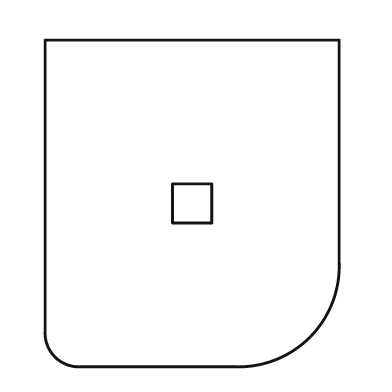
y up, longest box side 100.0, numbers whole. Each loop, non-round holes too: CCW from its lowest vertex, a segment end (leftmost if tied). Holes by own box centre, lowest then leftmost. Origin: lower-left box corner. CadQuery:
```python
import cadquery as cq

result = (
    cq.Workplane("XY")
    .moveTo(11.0, 0.0)
    .lineTo(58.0, 0.0)
    .threePointArc((81.0, 9.0), (90.0, 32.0))
    .lineTo(90.0, 100.0)
    .lineTo(0.0, 100.0)
    .lineTo(0.0, 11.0)
    .threePointArc((3.0, 3.0), (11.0, 0.0))
    .close()
    .moveTo(39.0, 44.0)
    .lineTo(51.0, 44.0)
    .lineTo(51.0, 56.0)
    .lineTo(39.0, 56.0)
    .close()
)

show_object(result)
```